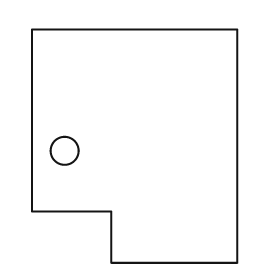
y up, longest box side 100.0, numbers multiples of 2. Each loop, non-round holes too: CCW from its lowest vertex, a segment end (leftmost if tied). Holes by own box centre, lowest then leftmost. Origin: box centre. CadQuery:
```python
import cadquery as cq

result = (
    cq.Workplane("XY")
    .moveTo(-10.0, -50.0)
    .lineTo(44.0, -50.0)
    .lineTo(44.0, 50.0)
    .lineTo(-44.0, 50.0)
    .lineTo(-44.0, -28.0)
    .lineTo(-10.0, -28.0)
    .close()
    .moveTo(-30.0, -2.0)
    .circle(6.0)
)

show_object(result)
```